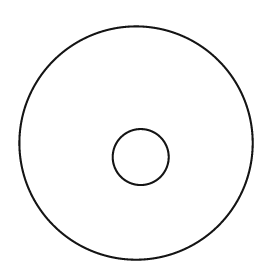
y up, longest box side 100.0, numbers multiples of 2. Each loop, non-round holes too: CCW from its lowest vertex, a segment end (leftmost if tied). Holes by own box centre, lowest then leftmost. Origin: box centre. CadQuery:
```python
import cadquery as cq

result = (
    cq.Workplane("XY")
    .moveTo(0.0, 0.0)
    .circle(50.0)
    .moveTo(2.0, -6.0)
    .circle(12.0)
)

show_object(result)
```